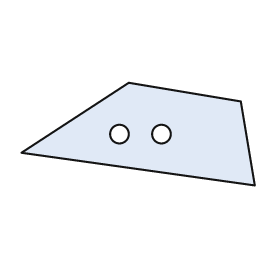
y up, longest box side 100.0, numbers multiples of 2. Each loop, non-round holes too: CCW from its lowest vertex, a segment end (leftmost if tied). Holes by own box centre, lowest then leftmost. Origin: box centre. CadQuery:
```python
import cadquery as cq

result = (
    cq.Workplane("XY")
    .moveTo(50.0, -22.0)
    .lineTo(44.0, 14.0)
    .lineTo(-4.0, 22.0)
    .lineTo(-50.0, -8.0)
    .close()
    .moveTo(-8.0, 0.0)
    .circle(4.0)
    .moveTo(10.0, 0.0)
    .circle(4.0)
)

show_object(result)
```